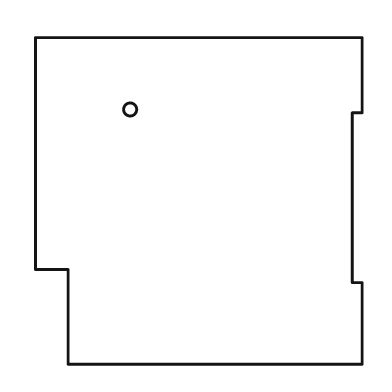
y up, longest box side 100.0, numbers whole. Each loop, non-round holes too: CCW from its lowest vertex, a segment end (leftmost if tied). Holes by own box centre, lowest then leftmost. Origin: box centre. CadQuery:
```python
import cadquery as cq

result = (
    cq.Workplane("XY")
    .moveTo(-40.0, -50.0)
    .lineTo(50.0, -50.0)
    .lineTo(50.0, -25.0)
    .lineTo(47.0, -25.0)
    .lineTo(47.0, 27.0)
    .lineTo(50.0, 27.0)
    .lineTo(50.0, 50.0)
    .lineTo(-50.0, 50.0)
    .lineTo(-50.0, -21.0)
    .lineTo(-40.0, -21.0)
    .close()
    .moveTo(-21.0, 28.0)
    .circle(2.0)
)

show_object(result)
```